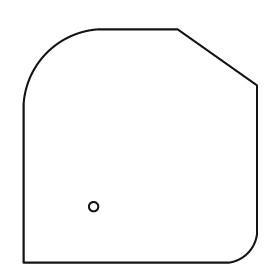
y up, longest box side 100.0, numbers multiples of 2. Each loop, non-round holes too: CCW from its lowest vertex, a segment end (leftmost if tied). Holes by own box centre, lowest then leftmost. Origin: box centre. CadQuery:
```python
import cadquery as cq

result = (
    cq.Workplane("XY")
    .moveTo(-50.0, -50.0)
    .lineTo(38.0, -50.0)
    .threePointArc((46.0, -46.0), (50.0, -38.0))
    .lineTo(50.0, 26.0)
    .lineTo(16.0, 50.0)
    .lineTo(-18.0, 50.0)
    .threePointArc((-40.0, 40.0), (-50.0, 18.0))
    .close()
    .moveTo(-20.0, -26.0)
    .circle(2.0)
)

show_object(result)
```